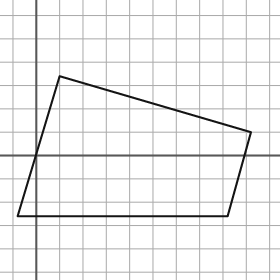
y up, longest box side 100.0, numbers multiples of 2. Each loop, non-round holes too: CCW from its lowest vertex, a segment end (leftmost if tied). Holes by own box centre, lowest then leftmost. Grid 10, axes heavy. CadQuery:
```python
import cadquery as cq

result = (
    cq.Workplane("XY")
    .moveTo(-8.0, -26.0)
    .lineTo(82.0, -26.0)
    .lineTo(92.0, 10.0)
    .lineTo(10.0, 34.0)
    .close()
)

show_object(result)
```